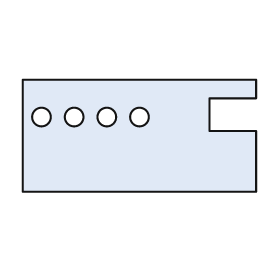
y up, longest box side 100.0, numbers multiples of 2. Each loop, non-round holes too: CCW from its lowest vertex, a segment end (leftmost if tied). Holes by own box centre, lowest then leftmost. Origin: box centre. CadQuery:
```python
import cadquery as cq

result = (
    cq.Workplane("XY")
    .moveTo(-50.0, -24.0)
    .lineTo(50.0, -24.0)
    .lineTo(50.0, 2.0)
    .lineTo(30.0, 2.0)
    .lineTo(30.0, 16.0)
    .lineTo(50.0, 16.0)
    .lineTo(50.0, 24.0)
    .lineTo(-50.0, 24.0)
    .close()
    .moveTo(-42.0, 8.0)
    .circle(4.0)
    .moveTo(-28.0, 8.0)
    .circle(4.0)
    .moveTo(-14.0, 8.0)
    .circle(4.0)
    .moveTo(0.0, 8.0)
    .circle(4.0)
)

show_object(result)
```